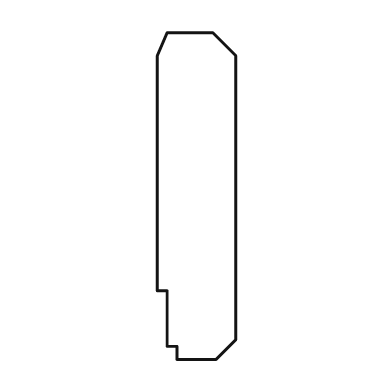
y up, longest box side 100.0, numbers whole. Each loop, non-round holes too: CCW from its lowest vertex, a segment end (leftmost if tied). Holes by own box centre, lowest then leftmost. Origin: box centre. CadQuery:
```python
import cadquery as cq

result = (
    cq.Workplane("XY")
    .moveTo(-6.0, -50.0)
    .lineTo(6.0, -50.0)
    .lineTo(12.0, -44.0)
    .lineTo(12.0, 43.0)
    .lineTo(5.0, 50.0)
    .lineTo(-9.0, 50.0)
    .lineTo(-12.0, 43.0)
    .lineTo(-12.0, -29.0)
    .lineTo(-9.0, -29.0)
    .lineTo(-9.0, -46.0)
    .lineTo(-6.0, -46.0)
    .close()
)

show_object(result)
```